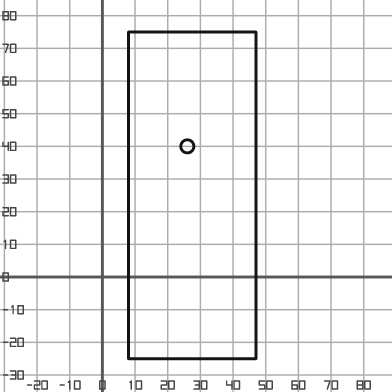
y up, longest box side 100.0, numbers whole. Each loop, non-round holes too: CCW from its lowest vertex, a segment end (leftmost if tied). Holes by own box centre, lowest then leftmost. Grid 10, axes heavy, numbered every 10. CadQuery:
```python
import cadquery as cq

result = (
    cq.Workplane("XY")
    .moveTo(8.0, -25.0)
    .lineTo(47.0, -25.0)
    .lineTo(47.0, 75.0)
    .lineTo(8.0, 75.0)
    .close()
    .moveTo(26.0, 40.0)
    .circle(2.0)
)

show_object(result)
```